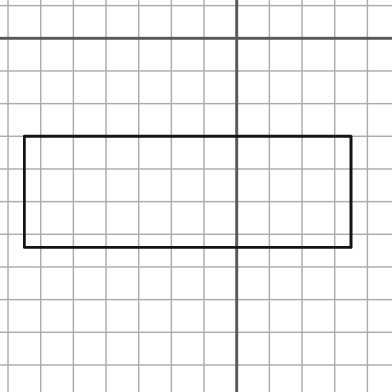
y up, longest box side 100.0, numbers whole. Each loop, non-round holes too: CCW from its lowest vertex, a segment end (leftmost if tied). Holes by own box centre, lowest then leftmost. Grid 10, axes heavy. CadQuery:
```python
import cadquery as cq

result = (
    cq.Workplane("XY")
    .moveTo(-65.0, -64.0)
    .lineTo(35.0, -64.0)
    .lineTo(35.0, -30.0)
    .lineTo(-65.0, -30.0)
    .close()
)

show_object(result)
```